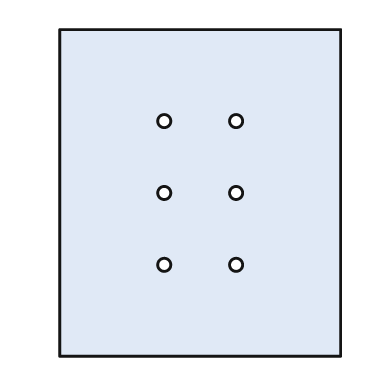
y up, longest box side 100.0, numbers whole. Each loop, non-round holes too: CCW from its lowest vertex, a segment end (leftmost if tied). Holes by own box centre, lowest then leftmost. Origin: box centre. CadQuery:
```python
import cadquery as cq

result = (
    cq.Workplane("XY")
    .moveTo(-43.0, -50.0)
    .lineTo(43.0, -50.0)
    .lineTo(43.0, 50.0)
    .lineTo(-43.0, 50.0)
    .close()
    .moveTo(-11.0, -22.0)
    .circle(2.0)
    .moveTo(11.0, -22.0)
    .circle(2.0)
    .moveTo(-11.0, 0.0)
    .circle(2.0)
    .moveTo(11.0, 0.0)
    .circle(2.0)
    .moveTo(-11.0, 22.0)
    .circle(2.0)
    .moveTo(11.0, 22.0)
    .circle(2.0)
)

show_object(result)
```